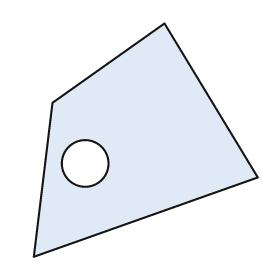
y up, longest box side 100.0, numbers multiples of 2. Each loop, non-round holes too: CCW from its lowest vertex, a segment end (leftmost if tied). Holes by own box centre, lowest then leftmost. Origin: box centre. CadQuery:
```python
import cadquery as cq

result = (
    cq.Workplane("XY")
    .moveTo(-48.0, -50.0)
    .lineTo(48.0, -16.0)
    .lineTo(8.0, 50.0)
    .lineTo(-40.0, 16.0)
    .close()
    .moveTo(-26.0, -10.0)
    .circle(10.0)
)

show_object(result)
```